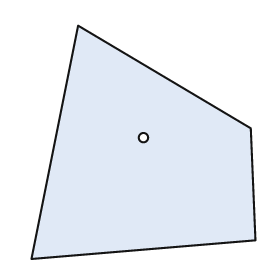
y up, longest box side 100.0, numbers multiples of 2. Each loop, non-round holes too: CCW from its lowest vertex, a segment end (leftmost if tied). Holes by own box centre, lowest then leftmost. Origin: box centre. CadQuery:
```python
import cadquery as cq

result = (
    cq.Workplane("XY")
    .moveTo(-48.0, -50.0)
    .lineTo(48.0, -42.0)
    .lineTo(46.0, 6.0)
    .lineTo(-28.0, 50.0)
    .close()
    .moveTo(0.0, 2.0)
    .circle(2.0)
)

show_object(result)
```